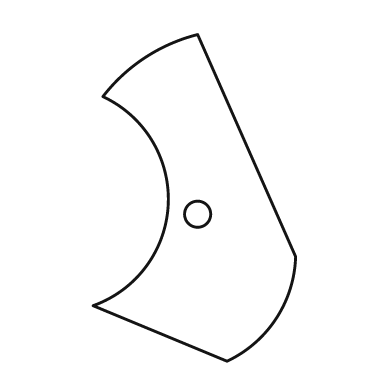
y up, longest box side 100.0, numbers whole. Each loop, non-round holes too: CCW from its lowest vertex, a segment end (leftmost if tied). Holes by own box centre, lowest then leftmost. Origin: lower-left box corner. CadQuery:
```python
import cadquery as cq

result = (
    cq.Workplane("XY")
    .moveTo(41.0, 0.0)
    .threePointArc((56.0, 13.0), (62.0, 32.0))
    .lineTo(32.0, 100.0)
    .threePointArc((16.0, 93.0), (3.0, 81.0))
    .threePointArc((23.0, 48.0), (0.0, 17.0))
    .close()
    .moveTo(32.0, 45.0)
    .circle(4.0)
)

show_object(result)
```